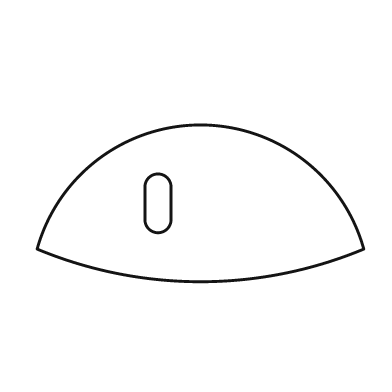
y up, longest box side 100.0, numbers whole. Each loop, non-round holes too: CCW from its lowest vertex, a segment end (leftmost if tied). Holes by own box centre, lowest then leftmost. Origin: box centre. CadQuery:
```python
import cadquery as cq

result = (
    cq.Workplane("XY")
    .moveTo(-50.0, -14.0)
    .threePointArc((0.0, -24.0), (50.0, -14.0))
    .threePointArc((0.0, 24.0), (-50.0, -14.0))
    .close()
    .moveTo(-17.0, -5.0)
    .threePointArc((-13.0, -9.0), (-9.0, -5.0))
    .lineTo(-9.0, 5.0)
    .threePointArc((-13.0, 9.0), (-17.0, 5.0))
    .close()
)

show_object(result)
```